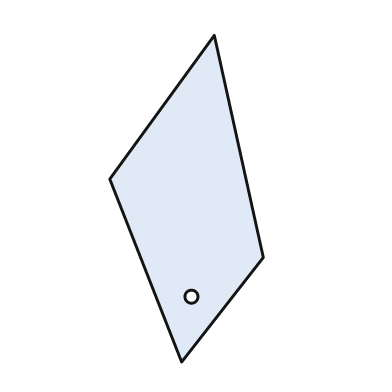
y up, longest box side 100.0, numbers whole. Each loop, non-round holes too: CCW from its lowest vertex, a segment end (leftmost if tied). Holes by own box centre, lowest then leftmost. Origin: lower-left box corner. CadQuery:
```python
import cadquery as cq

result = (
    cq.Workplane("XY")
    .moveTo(22.0, 0.0)
    .lineTo(47.0, 32.0)
    .lineTo(32.0, 100.0)
    .lineTo(0.0, 56.0)
    .close()
    .moveTo(25.0, 20.0)
    .circle(2.0)
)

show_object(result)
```